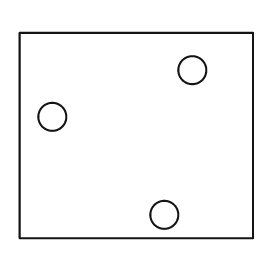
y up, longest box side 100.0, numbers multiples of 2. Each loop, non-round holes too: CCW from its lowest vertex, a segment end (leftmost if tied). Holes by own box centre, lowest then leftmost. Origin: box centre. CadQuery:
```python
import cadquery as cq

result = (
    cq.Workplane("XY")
    .moveTo(-50.0, -44.0)
    .lineTo(50.0, -44.0)
    .lineTo(50.0, 44.0)
    .lineTo(-50.0, 44.0)
    .close()
    .moveTo(12.0, -34.0)
    .circle(6.0)
    .moveTo(-36.0, 8.0)
    .circle(6.0)
    .moveTo(24.0, 28.0)
    .circle(6.0)
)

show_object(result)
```